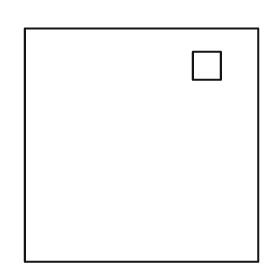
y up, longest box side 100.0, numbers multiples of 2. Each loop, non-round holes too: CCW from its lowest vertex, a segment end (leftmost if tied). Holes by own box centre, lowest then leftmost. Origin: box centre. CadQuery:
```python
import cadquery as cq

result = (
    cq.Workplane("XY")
    .moveTo(-50.0, -50.0)
    .lineTo(50.0, -50.0)
    .lineTo(50.0, 50.0)
    .lineTo(-50.0, 50.0)
    .close()
    .moveTo(22.0, 28.0)
    .lineTo(34.0, 28.0)
    .lineTo(34.0, 40.0)
    .lineTo(22.0, 40.0)
    .close()
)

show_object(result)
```